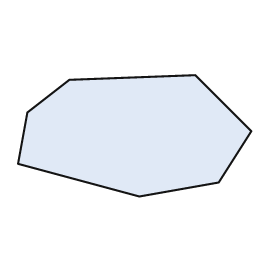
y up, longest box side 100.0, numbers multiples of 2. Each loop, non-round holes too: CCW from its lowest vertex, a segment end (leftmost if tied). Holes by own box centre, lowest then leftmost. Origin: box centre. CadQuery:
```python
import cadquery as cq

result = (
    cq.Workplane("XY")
    .moveTo(2.0, -26.0)
    .lineTo(36.0, -20.0)
    .lineTo(50.0, 2.0)
    .lineTo(26.0, 26.0)
    .lineTo(-28.0, 24.0)
    .lineTo(-46.0, 10.0)
    .lineTo(-50.0, -12.0)
    .close()
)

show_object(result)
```